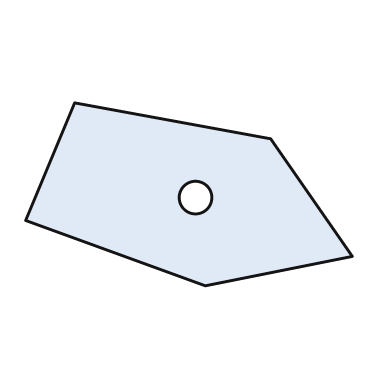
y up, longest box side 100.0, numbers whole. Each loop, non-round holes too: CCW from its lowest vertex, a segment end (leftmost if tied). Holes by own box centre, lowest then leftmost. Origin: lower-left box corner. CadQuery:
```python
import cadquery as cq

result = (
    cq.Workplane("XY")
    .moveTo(55.0, 0.0)
    .lineTo(100.0, 9.0)
    .lineTo(75.0, 45.0)
    .lineTo(15.0, 56.0)
    .lineTo(0.0, 20.0)
    .close()
    .moveTo(52.0, 27.0)
    .circle(5.0)
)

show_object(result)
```